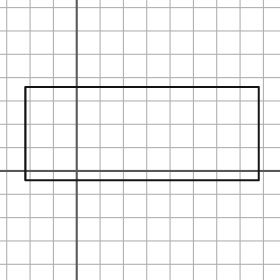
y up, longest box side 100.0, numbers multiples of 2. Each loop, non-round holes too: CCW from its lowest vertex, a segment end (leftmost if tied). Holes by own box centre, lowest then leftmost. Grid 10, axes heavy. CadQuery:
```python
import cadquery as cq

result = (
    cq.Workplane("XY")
    .moveTo(-22.0, -4.0)
    .lineTo(78.0, -4.0)
    .lineTo(78.0, 36.0)
    .lineTo(-22.0, 36.0)
    .close()
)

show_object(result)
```